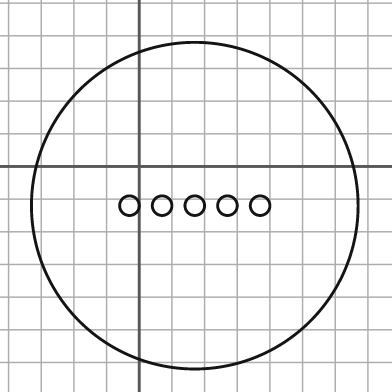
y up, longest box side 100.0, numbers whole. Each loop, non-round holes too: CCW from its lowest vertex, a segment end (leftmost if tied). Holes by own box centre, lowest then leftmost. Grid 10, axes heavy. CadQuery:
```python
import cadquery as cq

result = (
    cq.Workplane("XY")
    .moveTo(17.0, -12.0)
    .circle(50.0)
    .moveTo(-3.0, -12.0)
    .circle(3.0)
    .moveTo(7.0, -12.0)
    .circle(3.0)
    .moveTo(17.0, -12.0)
    .circle(3.0)
    .moveTo(27.0, -12.0)
    .circle(3.0)
    .moveTo(37.0, -12.0)
    .circle(3.0)
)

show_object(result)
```